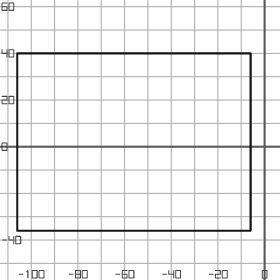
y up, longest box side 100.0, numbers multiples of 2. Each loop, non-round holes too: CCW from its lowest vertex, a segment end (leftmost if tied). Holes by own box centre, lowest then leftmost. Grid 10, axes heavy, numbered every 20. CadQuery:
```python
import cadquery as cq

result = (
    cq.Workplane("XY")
    .moveTo(-106.0, -36.0)
    .lineTo(-6.0, -36.0)
    .lineTo(-6.0, 40.0)
    .lineTo(-106.0, 40.0)
    .close()
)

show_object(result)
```